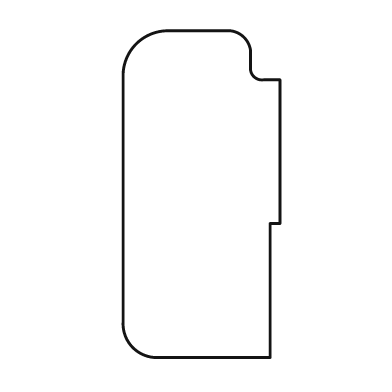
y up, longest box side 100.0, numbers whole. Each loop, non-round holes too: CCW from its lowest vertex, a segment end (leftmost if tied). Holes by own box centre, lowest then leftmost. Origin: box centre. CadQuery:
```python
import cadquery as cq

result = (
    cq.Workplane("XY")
    .moveTo(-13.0, -50.0)
    .lineTo(21.0, -50.0)
    .lineTo(21.0, -9.0)
    .lineTo(24.0, -9.0)
    .lineTo(24.0, 35.0)
    .lineTo(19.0, 35.0)
    .threePointArc((16.0, 36.0), (15.0, 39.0))
    .lineTo(15.0, 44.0)
    .threePointArc((13.0, 48.0), (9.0, 50.0))
    .lineTo(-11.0, 50.0)
    .threePointArc((-20.0, 46.0), (-24.0, 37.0))
    .lineTo(-24.0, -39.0)
    .threePointArc((-21.0, -47.0), (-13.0, -50.0))
    .close()
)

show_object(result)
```